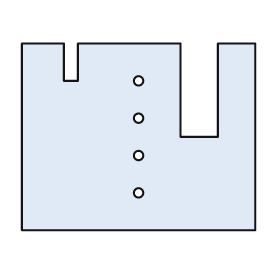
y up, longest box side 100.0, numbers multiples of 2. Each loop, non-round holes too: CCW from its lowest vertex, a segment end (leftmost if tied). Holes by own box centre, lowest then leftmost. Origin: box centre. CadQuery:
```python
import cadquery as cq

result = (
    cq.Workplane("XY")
    .moveTo(-50.0, -40.0)
    .lineTo(50.0, -40.0)
    .lineTo(50.0, 40.0)
    .lineTo(34.0, 40.0)
    .lineTo(34.0, 0.0)
    .lineTo(18.0, 0.0)
    .lineTo(18.0, 40.0)
    .lineTo(-26.0, 40.0)
    .lineTo(-26.0, 24.0)
    .lineTo(-32.0, 24.0)
    .lineTo(-32.0, 40.0)
    .lineTo(-50.0, 40.0)
    .close()
    .moveTo(0.0, -24.0)
    .circle(2.0)
    .moveTo(0.0, -8.0)
    .circle(2.0)
    .moveTo(0.0, 8.0)
    .circle(2.0)
    .moveTo(0.0, 24.0)
    .circle(2.0)
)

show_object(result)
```